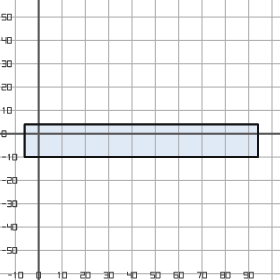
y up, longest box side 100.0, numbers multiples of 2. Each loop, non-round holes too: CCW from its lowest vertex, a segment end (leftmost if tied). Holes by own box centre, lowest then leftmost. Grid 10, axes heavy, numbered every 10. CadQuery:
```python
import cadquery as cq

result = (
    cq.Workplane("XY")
    .moveTo(-6.0, -10.0)
    .lineTo(94.0, -10.0)
    .lineTo(94.0, 4.0)
    .lineTo(-6.0, 4.0)
    .close()
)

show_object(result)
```